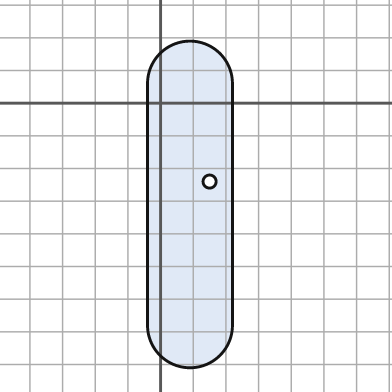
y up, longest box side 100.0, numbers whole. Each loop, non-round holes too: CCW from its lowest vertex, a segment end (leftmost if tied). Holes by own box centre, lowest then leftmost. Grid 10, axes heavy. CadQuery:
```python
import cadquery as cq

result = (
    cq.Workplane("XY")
    .moveTo(-4.0, -68.0)
    .threePointArc((9.0, -81.0), (22.0, -68.0))
    .lineTo(22.0, 6.0)
    .threePointArc((9.0, 19.0), (-4.0, 6.0))
    .close()
    .moveTo(15.0, -24.0)
    .circle(2.0)
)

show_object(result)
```